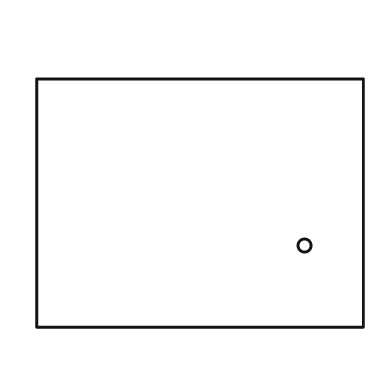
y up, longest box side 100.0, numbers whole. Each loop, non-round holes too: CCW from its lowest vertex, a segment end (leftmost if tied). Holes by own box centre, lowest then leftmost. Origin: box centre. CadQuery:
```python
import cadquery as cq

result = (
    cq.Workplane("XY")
    .moveTo(-50.0, -38.0)
    .lineTo(50.0, -38.0)
    .lineTo(50.0, 38.0)
    .lineTo(-50.0, 38.0)
    .close()
    .moveTo(32.0, -13.0)
    .circle(2.0)
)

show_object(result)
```